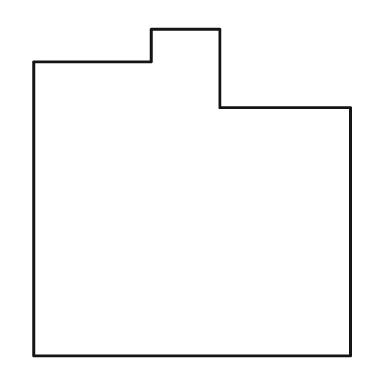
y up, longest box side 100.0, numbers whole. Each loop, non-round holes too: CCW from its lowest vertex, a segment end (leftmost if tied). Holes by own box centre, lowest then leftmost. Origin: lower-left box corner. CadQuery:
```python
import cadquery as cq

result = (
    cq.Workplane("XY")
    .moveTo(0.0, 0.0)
    .lineTo(97.0, 0.0)
    .lineTo(97.0, 76.0)
    .lineTo(57.0, 76.0)
    .lineTo(57.0, 100.0)
    .lineTo(36.0, 100.0)
    .lineTo(36.0, 90.0)
    .lineTo(0.0, 90.0)
    .close()
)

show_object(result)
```